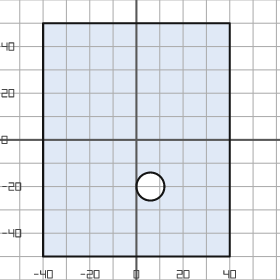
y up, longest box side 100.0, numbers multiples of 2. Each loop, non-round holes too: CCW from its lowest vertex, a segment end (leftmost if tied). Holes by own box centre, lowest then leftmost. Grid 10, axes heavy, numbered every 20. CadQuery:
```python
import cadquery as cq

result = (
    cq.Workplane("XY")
    .moveTo(-40.0, -50.0)
    .lineTo(40.0, -50.0)
    .lineTo(40.0, 50.0)
    .lineTo(-40.0, 50.0)
    .close()
    .moveTo(6.0, -20.0)
    .circle(6.0)
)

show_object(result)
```